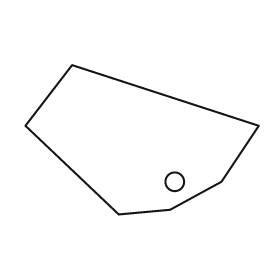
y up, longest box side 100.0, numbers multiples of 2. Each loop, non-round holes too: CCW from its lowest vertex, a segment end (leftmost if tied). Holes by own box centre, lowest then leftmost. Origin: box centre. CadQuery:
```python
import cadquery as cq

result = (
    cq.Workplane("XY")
    .moveTo(-10.0, -32.0)
    .lineTo(12.0, -30.0)
    .lineTo(34.0, -18.0)
    .lineTo(50.0, 6.0)
    .lineTo(-30.0, 32.0)
    .lineTo(-50.0, 6.0)
    .close()
    .moveTo(14.0, -18.0)
    .circle(4.0)
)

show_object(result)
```